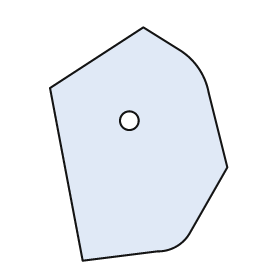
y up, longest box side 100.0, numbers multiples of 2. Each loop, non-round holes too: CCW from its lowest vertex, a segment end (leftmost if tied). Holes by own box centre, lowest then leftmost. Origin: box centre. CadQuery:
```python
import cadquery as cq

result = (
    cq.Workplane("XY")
    .moveTo(-24.0, -50.0)
    .lineTo(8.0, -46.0)
    .threePointArc((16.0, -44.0), (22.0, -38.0))
    .lineTo(38.0, -10.0)
    .lineTo(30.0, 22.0)
    .threePointArc((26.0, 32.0), (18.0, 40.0))
    .lineTo(2.0, 50.0)
    .lineTo(-38.0, 24.0)
    .close()
    .moveTo(-4.0, 10.0)
    .circle(4.0)
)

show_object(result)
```